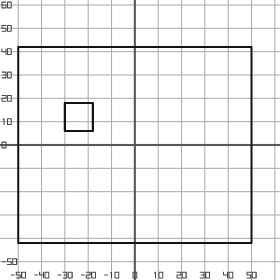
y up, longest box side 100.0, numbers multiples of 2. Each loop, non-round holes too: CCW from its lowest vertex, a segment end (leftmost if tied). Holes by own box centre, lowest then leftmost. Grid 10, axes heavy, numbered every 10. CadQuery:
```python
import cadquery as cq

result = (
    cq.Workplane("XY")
    .moveTo(-50.0, -42.0)
    .lineTo(50.0, -42.0)
    .lineTo(50.0, 42.0)
    .lineTo(-50.0, 42.0)
    .close()
    .moveTo(-30.0, 6.0)
    .lineTo(-18.0, 6.0)
    .lineTo(-18.0, 18.0)
    .lineTo(-30.0, 18.0)
    .close()
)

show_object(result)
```